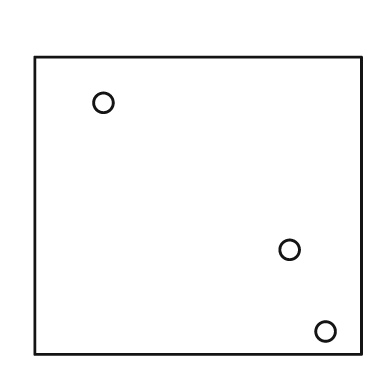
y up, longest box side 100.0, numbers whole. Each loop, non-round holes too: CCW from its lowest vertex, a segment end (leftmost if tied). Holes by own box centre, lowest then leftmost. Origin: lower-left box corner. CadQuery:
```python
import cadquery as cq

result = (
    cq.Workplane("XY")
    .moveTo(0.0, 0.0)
    .lineTo(100.0, 0.0)
    .lineTo(100.0, 91.0)
    .lineTo(0.0, 91.0)
    .close()
    .moveTo(89.0, 7.0)
    .circle(3.0)
    .moveTo(78.0, 32.0)
    .circle(3.0)
    .moveTo(21.0, 77.0)
    .circle(3.0)
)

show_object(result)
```